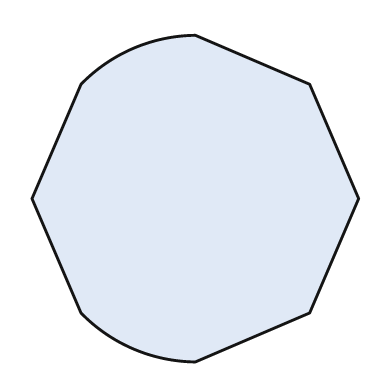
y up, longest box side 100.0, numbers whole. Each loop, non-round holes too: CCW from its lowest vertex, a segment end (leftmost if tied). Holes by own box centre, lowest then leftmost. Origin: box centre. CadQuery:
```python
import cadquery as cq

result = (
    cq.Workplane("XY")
    .moveTo(0.0, -50.0)
    .lineTo(35.0, -35.0)
    .lineTo(50.0, 0.0)
    .lineTo(35.0, 35.0)
    .lineTo(0.0, 50.0)
    .threePointArc((-19.0, 46.0), (-35.0, 35.0))
    .lineTo(-50.0, 0.0)
    .lineTo(-35.0, -35.0)
    .threePointArc((-19.0, -46.0), (0.0, -50.0))
    .close()
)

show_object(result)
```